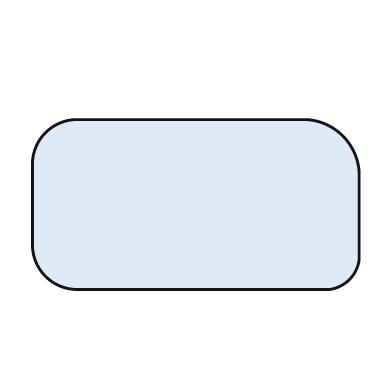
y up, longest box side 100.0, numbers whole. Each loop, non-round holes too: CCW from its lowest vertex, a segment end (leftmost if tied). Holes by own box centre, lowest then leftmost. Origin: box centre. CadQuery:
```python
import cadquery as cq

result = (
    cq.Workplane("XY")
    .moveTo(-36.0, -26.0)
    .lineTo(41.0, -26.0)
    .threePointArc((47.0, -23.0), (50.0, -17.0))
    .lineTo(50.0, 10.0)
    .threePointArc((45.0, 21.0), (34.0, 26.0))
    .lineTo(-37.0, 26.0)
    .threePointArc((-46.0, 22.0), (-50.0, 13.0))
    .lineTo(-50.0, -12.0)
    .threePointArc((-46.0, -22.0), (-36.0, -26.0))
    .close()
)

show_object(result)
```